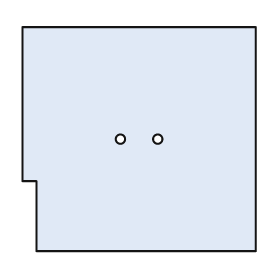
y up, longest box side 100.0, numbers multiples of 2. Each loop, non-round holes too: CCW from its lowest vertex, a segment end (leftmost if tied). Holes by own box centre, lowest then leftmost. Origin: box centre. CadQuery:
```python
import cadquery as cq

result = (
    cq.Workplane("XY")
    .moveTo(-44.0, -48.0)
    .lineTo(50.0, -48.0)
    .lineTo(50.0, 48.0)
    .lineTo(-50.0, 48.0)
    .lineTo(-50.0, -18.0)
    .lineTo(-44.0, -18.0)
    .close()
    .moveTo(-8.0, 0.0)
    .circle(2.0)
    .moveTo(8.0, 0.0)
    .circle(2.0)
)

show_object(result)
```